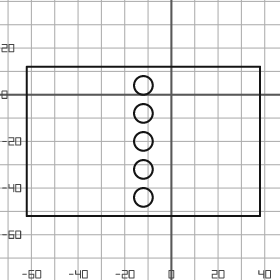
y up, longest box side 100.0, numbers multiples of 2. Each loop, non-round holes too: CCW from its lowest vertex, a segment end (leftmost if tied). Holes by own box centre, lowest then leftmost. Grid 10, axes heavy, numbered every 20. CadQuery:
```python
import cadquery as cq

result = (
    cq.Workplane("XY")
    .moveTo(-62.0, -52.0)
    .lineTo(38.0, -52.0)
    .lineTo(38.0, 12.0)
    .lineTo(-62.0, 12.0)
    .close()
    .moveTo(-12.0, -44.0)
    .circle(4.0)
    .moveTo(-12.0, -32.0)
    .circle(4.0)
    .moveTo(-12.0, -20.0)
    .circle(4.0)
    .moveTo(-12.0, -8.0)
    .circle(4.0)
    .moveTo(-12.0, 4.0)
    .circle(4.0)
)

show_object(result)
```